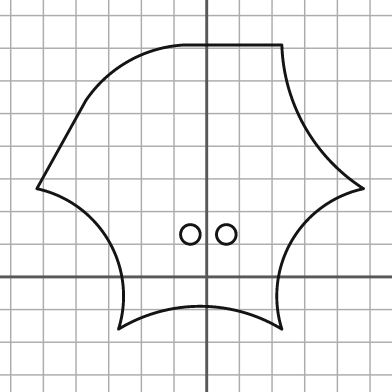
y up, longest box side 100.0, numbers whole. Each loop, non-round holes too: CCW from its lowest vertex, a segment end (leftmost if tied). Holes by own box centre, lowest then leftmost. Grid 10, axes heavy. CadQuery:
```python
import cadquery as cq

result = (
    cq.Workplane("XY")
    .moveTo(-27.0, -16.0)
    .threePointArc((-2.0, -9.0), (23.0, -16.0))
    .threePointArc((26.0, 11.0), (48.0, 27.0))
    .threePointArc((30.0, 46.0), (23.0, 71.0))
    .lineTo(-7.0, 71.0)
    .threePointArc((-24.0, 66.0), (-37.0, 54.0))
    .lineTo(-52.0, 27.0)
    .threePointArc((-30.0, 11.0), (-27.0, -16.0))
    .close()
    .moveTo(-5.0, 13.0)
    .circle(3.0)
    .moveTo(6.0, 13.0)
    .circle(3.0)
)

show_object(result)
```